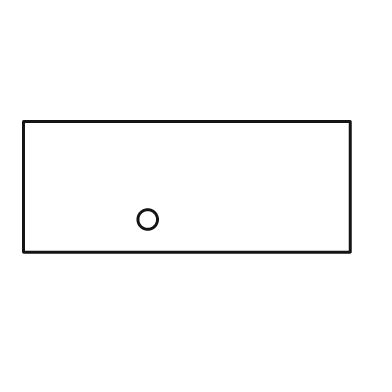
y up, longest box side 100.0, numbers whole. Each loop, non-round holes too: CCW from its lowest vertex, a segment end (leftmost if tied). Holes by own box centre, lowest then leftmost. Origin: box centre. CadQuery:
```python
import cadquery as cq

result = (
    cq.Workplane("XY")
    .moveTo(-50.0, -20.0)
    .lineTo(50.0, -20.0)
    .lineTo(50.0, 20.0)
    .lineTo(-50.0, 20.0)
    .close()
    .moveTo(-12.0, -10.0)
    .circle(3.0)
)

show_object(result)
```